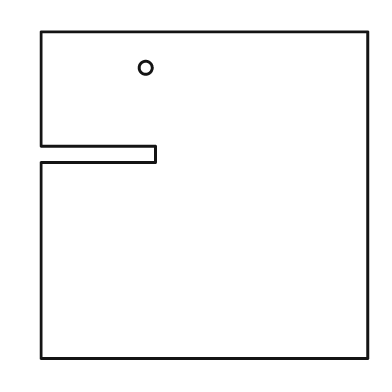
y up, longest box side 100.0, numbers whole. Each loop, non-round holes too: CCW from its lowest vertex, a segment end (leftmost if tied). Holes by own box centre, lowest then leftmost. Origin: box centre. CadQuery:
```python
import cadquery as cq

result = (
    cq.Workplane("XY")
    .moveTo(-50.0, -50.0)
    .lineTo(50.0, -50.0)
    .lineTo(50.0, 50.0)
    .lineTo(-50.0, 50.0)
    .lineTo(-50.0, 15.0)
    .lineTo(-15.0, 15.0)
    .lineTo(-15.0, 10.0)
    .lineTo(-50.0, 10.0)
    .close()
    .moveTo(-18.0, 39.0)
    .circle(2.0)
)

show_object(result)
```